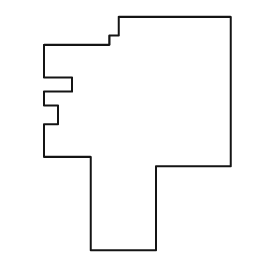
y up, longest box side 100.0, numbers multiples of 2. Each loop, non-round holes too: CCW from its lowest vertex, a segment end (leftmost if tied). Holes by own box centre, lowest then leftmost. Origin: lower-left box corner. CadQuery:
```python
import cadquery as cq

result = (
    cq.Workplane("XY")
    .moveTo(20.0, 0.0)
    .lineTo(48.0, 0.0)
    .lineTo(48.0, 36.0)
    .lineTo(80.0, 36.0)
    .lineTo(80.0, 100.0)
    .lineTo(32.0, 100.0)
    .lineTo(32.0, 92.0)
    .lineTo(28.0, 92.0)
    .lineTo(28.0, 88.0)
    .lineTo(0.0, 88.0)
    .lineTo(0.0, 74.0)
    .lineTo(12.0, 74.0)
    .lineTo(12.0, 68.0)
    .lineTo(0.0, 68.0)
    .lineTo(0.0, 62.0)
    .lineTo(6.0, 62.0)
    .lineTo(6.0, 54.0)
    .lineTo(0.0, 54.0)
    .lineTo(0.0, 40.0)
    .lineTo(20.0, 40.0)
    .close()
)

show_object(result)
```